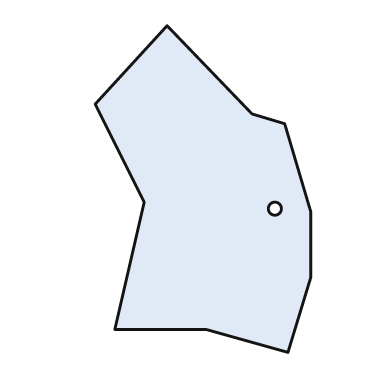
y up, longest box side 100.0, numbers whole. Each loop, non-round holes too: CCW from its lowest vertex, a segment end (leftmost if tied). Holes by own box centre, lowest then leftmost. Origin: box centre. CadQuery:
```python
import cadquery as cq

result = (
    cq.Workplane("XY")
    .moveTo(26.0, -50.0)
    .lineTo(33.0, -27.0)
    .lineTo(33.0, -7.0)
    .lineTo(25.0, 20.0)
    .lineTo(15.0, 23.0)
    .lineTo(-11.0, 50.0)
    .lineTo(-33.0, 26.0)
    .lineTo(-18.0, -4.0)
    .lineTo(-27.0, -43.0)
    .lineTo(1.0, -43.0)
    .close()
    .moveTo(22.0, -6.0)
    .circle(2.0)
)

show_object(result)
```